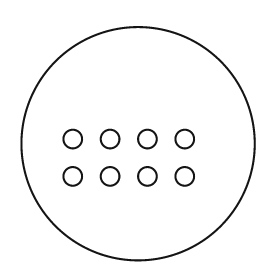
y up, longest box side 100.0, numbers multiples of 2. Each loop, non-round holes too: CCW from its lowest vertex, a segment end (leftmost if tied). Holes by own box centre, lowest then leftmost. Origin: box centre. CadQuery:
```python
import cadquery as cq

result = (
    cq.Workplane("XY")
    .moveTo(0.0, 0.0)
    .circle(50.0)
    .moveTo(-28.0, -14.0)
    .circle(4.0)
    .moveTo(-12.0, -14.0)
    .circle(4.0)
    .moveTo(4.0, -14.0)
    .circle(4.0)
    .moveTo(20.0, -14.0)
    .circle(4.0)
    .moveTo(-28.0, 2.0)
    .circle(4.0)
    .moveTo(-12.0, 2.0)
    .circle(4.0)
    .moveTo(4.0, 2.0)
    .circle(4.0)
    .moveTo(20.0, 2.0)
    .circle(4.0)
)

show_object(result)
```